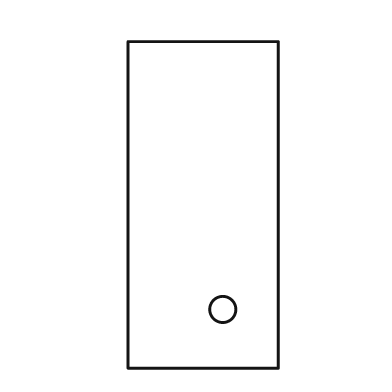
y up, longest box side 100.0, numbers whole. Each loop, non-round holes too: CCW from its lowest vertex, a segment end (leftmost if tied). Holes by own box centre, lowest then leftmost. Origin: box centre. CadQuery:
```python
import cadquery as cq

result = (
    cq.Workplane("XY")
    .moveTo(-23.0, -50.0)
    .lineTo(23.0, -50.0)
    .lineTo(23.0, 50.0)
    .lineTo(-23.0, 50.0)
    .close()
    .moveTo(6.0, -32.0)
    .circle(4.0)
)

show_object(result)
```